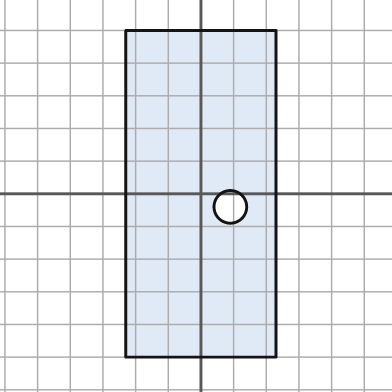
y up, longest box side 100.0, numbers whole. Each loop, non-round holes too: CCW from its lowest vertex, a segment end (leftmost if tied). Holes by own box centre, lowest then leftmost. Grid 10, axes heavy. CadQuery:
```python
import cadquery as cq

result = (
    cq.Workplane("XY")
    .moveTo(-23.0, -50.0)
    .lineTo(23.0, -50.0)
    .lineTo(23.0, 50.0)
    .lineTo(-23.0, 50.0)
    .close()
    .moveTo(9.0, -4.0)
    .circle(5.0)
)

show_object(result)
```